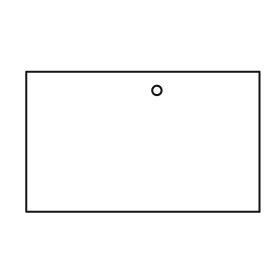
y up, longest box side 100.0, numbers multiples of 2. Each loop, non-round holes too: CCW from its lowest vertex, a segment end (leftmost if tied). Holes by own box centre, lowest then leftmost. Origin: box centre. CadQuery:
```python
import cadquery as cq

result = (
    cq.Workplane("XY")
    .moveTo(-50.0, -30.0)
    .lineTo(50.0, -30.0)
    .lineTo(50.0, 30.0)
    .lineTo(-50.0, 30.0)
    .close()
    .moveTo(6.0, 22.0)
    .circle(2.0)
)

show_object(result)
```